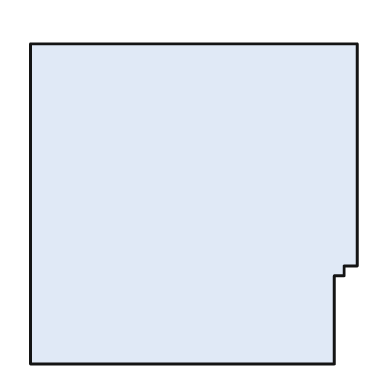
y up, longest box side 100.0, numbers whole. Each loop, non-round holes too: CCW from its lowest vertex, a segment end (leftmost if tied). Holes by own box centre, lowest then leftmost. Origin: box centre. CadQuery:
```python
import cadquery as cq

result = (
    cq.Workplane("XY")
    .moveTo(-50.0, -49.0)
    .lineTo(43.0, -49.0)
    .lineTo(43.0, -22.0)
    .lineTo(46.0, -22.0)
    .lineTo(46.0, -19.0)
    .lineTo(50.0, -19.0)
    .lineTo(50.0, 49.0)
    .lineTo(-50.0, 49.0)
    .close()
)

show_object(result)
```